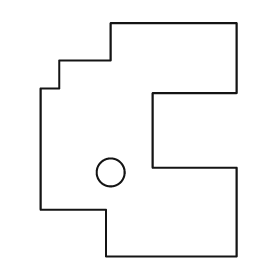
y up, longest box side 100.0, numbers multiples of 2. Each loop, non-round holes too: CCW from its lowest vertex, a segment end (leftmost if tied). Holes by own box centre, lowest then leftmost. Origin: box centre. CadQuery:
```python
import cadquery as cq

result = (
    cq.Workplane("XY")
    .moveTo(-14.0, -50.0)
    .lineTo(42.0, -50.0)
    .lineTo(42.0, -12.0)
    .lineTo(6.0, -12.0)
    .lineTo(6.0, 20.0)
    .lineTo(42.0, 20.0)
    .lineTo(42.0, 50.0)
    .lineTo(-12.0, 50.0)
    .lineTo(-12.0, 34.0)
    .lineTo(-34.0, 34.0)
    .lineTo(-34.0, 22.0)
    .lineTo(-42.0, 22.0)
    .lineTo(-42.0, -30.0)
    .lineTo(-14.0, -30.0)
    .close()
    .moveTo(-12.0, -14.0)
    .circle(6.0)
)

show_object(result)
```